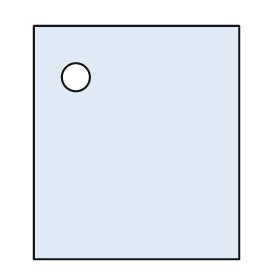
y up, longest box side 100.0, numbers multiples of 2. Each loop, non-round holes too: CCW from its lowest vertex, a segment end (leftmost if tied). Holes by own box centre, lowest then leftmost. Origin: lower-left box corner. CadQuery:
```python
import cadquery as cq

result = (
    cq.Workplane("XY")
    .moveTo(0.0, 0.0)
    .lineTo(88.0, 0.0)
    .lineTo(88.0, 100.0)
    .lineTo(0.0, 100.0)
    .close()
    .moveTo(18.0, 78.0)
    .circle(6.0)
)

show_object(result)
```